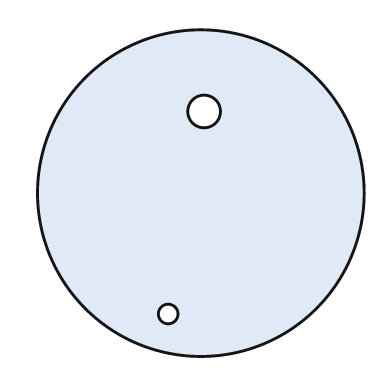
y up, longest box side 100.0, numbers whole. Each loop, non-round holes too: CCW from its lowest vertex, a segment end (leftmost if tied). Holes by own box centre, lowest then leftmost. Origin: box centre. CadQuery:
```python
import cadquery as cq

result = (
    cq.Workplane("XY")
    .moveTo(0.0, 0.0)
    .circle(50.0)
    .moveTo(-10.0, -37.0)
    .circle(3.0)
    .moveTo(1.0, 25.0)
    .circle(5.0)
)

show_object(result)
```